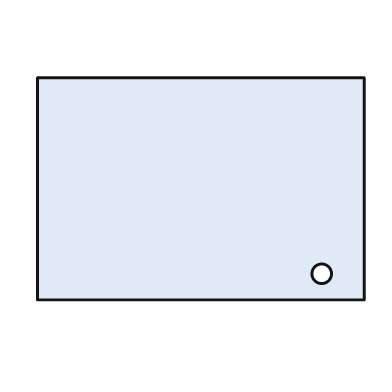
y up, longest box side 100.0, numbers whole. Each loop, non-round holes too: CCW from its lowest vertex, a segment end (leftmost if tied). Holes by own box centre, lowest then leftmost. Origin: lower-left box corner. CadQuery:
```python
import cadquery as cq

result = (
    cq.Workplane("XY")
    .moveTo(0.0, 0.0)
    .lineTo(100.0, 0.0)
    .lineTo(100.0, 68.0)
    .lineTo(0.0, 68.0)
    .close()
    .moveTo(87.0, 8.0)
    .circle(3.0)
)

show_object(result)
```